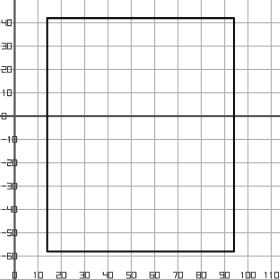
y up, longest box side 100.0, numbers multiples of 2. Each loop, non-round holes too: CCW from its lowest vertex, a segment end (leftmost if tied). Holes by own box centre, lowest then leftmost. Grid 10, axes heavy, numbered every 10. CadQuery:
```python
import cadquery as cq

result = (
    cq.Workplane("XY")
    .moveTo(14.0, -58.0)
    .lineTo(94.0, -58.0)
    .lineTo(94.0, 42.0)
    .lineTo(14.0, 42.0)
    .close()
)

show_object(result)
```